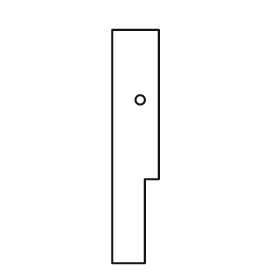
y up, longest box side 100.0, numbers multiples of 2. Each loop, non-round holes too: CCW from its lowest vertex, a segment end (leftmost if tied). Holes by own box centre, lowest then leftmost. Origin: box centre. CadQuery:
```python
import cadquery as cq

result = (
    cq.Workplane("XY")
    .moveTo(-10.0, -50.0)
    .lineTo(4.0, -50.0)
    .lineTo(4.0, -14.0)
    .lineTo(10.0, -14.0)
    .lineTo(10.0, 50.0)
    .lineTo(-10.0, 50.0)
    .close()
    .moveTo(2.0, 20.0)
    .circle(2.0)
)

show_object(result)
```